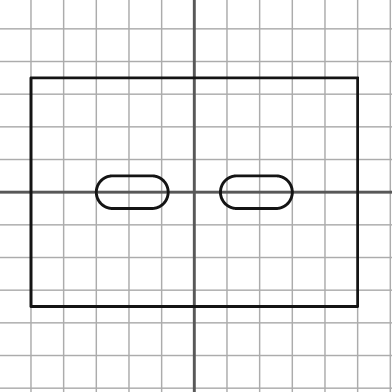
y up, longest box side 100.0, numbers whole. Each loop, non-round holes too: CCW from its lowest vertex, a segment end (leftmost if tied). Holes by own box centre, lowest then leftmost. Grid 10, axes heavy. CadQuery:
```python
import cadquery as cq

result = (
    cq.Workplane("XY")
    .moveTo(-50.0, -35.0)
    .lineTo(50.0, -35.0)
    .lineTo(50.0, 35.0)
    .lineTo(-50.0, 35.0)
    .close()
    .moveTo(-25.0, -5.0)
    .lineTo(-13.0, -5.0)
    .threePointArc((-8.0, 0.0), (-13.0, 5.0))
    .lineTo(-25.0, 5.0)
    .threePointArc((-30.0, 0.0), (-25.0, -5.0))
    .close()
    .moveTo(13.0, -5.0)
    .lineTo(25.0, -5.0)
    .threePointArc((30.0, 0.0), (25.0, 5.0))
    .lineTo(13.0, 5.0)
    .threePointArc((8.0, 0.0), (13.0, -5.0))
    .close()
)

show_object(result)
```